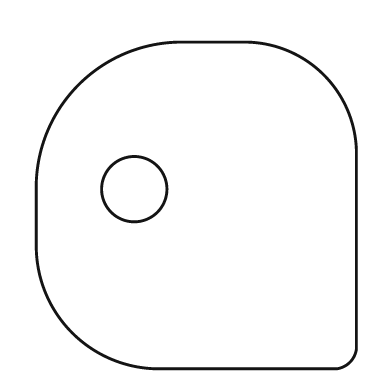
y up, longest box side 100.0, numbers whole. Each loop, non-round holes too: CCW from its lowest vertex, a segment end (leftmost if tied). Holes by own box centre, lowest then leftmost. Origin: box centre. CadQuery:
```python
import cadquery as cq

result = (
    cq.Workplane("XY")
    .moveTo(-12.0, -50.0)
    .lineTo(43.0, -50.0)
    .threePointArc((47.0, -48.0), (49.0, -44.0))
    .lineTo(49.0, 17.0)
    .threePointArc((39.0, 40.0), (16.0, 50.0))
    .lineTo(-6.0, 50.0)
    .threePointArc((-36.0, 37.0), (-49.0, 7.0))
    .lineTo(-49.0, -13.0)
    .threePointArc((-38.0, -39.0), (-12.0, -50.0))
    .close()
    .moveTo(-19.0, 5.0)
    .circle(10.0)
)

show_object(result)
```